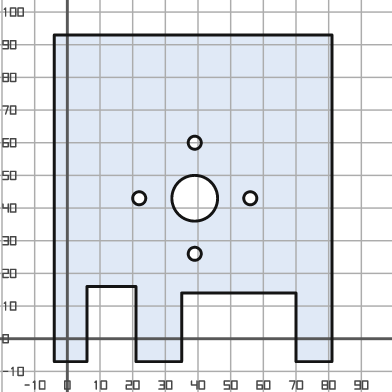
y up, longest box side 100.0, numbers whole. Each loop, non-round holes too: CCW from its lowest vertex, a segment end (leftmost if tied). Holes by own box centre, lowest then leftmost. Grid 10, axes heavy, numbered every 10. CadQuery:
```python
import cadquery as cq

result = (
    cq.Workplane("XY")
    .moveTo(-4.0, -7.0)
    .lineTo(6.0, -7.0)
    .lineTo(6.0, 16.0)
    .lineTo(21.0, 16.0)
    .lineTo(21.0, -7.0)
    .lineTo(35.0, -7.0)
    .lineTo(35.0, 14.0)
    .lineTo(70.0, 14.0)
    .lineTo(70.0, -7.0)
    .lineTo(81.0, -7.0)
    .lineTo(81.0, 93.0)
    .lineTo(-4.0, 93.0)
    .close()
    .moveTo(39.0, 26.0)
    .circle(2.0)
    .moveTo(22.0, 43.0)
    .circle(2.0)
    .moveTo(39.0, 43.0)
    .circle(7.0)
    .moveTo(56.0, 43.0)
    .circle(2.0)
    .moveTo(39.0, 60.0)
    .circle(2.0)
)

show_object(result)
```